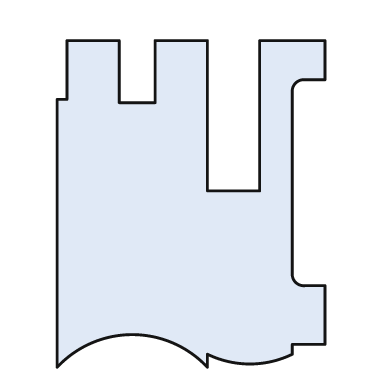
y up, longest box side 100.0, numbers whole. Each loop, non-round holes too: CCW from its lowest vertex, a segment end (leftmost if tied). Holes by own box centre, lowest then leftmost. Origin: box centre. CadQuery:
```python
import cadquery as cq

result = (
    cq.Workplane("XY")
    .moveTo(-41.0, -50.0)
    .threePointArc((-18.0, -40.0), (5.0, -50.0))
    .lineTo(5.0, -46.0)
    .threePointArc((18.0, -49.0), (31.0, -46.0))
    .lineTo(31.0, -43.0)
    .lineTo(41.0, -43.0)
    .lineTo(41.0, -25.0)
    .lineTo(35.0, -25.0)
    .threePointArc((32.0, -24.0), (31.0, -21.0))
    .lineTo(31.0, 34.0)
    .threePointArc((32.0, 37.0), (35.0, 38.0))
    .lineTo(41.0, 38.0)
    .lineTo(41.0, 50.0)
    .lineTo(21.0, 50.0)
    .lineTo(21.0, 4.0)
    .lineTo(5.0, 4.0)
    .lineTo(5.0, 50.0)
    .lineTo(-11.0, 50.0)
    .lineTo(-11.0, 31.0)
    .lineTo(-22.0, 31.0)
    .lineTo(-22.0, 50.0)
    .lineTo(-38.0, 50.0)
    .lineTo(-38.0, 32.0)
    .lineTo(-41.0, 32.0)
    .close()
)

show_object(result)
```